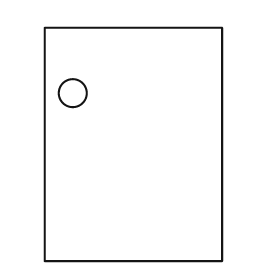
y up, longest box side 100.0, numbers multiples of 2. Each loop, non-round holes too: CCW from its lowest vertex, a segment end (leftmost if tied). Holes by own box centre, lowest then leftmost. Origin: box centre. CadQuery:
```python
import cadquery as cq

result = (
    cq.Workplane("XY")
    .moveTo(-38.0, -50.0)
    .lineTo(38.0, -50.0)
    .lineTo(38.0, 50.0)
    .lineTo(-38.0, 50.0)
    .close()
    .moveTo(-26.0, 22.0)
    .circle(6.0)
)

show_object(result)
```